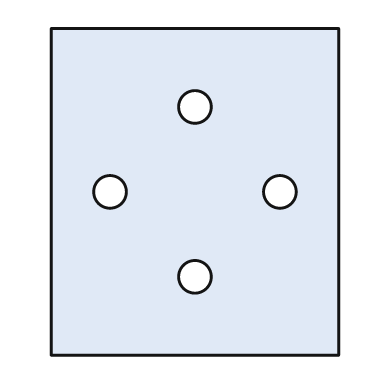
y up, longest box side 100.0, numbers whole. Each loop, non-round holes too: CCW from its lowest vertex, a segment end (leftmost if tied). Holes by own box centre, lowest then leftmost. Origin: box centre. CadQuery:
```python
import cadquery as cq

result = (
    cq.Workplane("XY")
    .moveTo(-44.0, -50.0)
    .lineTo(44.0, -50.0)
    .lineTo(44.0, 50.0)
    .lineTo(-44.0, 50.0)
    .close()
    .moveTo(0.0, -26.0)
    .circle(5.0)
    .moveTo(-26.0, 0.0)
    .circle(5.0)
    .moveTo(26.0, 0.0)
    .circle(5.0)
    .moveTo(0.0, 26.0)
    .circle(5.0)
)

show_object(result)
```